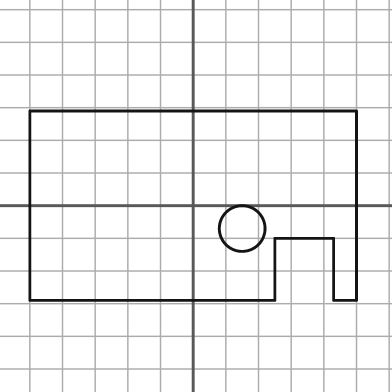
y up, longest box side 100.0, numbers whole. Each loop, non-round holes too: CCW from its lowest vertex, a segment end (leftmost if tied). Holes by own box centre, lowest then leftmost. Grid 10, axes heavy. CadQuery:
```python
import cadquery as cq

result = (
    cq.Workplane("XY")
    .moveTo(-50.0, -29.0)
    .lineTo(25.0, -29.0)
    .lineTo(25.0, -10.0)
    .lineTo(43.0, -10.0)
    .lineTo(43.0, -29.0)
    .lineTo(50.0, -29.0)
    .lineTo(50.0, 29.0)
    .lineTo(-50.0, 29.0)
    .close()
    .moveTo(15.0, -7.0)
    .circle(7.0)
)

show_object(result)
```